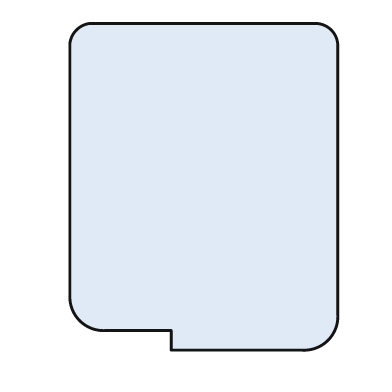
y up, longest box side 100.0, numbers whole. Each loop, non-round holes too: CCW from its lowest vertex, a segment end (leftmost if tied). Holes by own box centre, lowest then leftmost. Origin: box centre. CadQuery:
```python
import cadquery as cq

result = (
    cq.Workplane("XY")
    .moveTo(-10.0, -50.0)
    .lineTo(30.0, -50.0)
    .threePointArc((38.0, -47.0), (41.0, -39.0))
    .lineTo(41.0, 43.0)
    .threePointArc((39.0, 48.0), (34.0, 50.0))
    .lineTo(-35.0, 50.0)
    .threePointArc((-39.0, 48.0), (-41.0, 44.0))
    .lineTo(-41.0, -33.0)
    .threePointArc((-38.0, -41.0), (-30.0, -44.0))
    .lineTo(-10.0, -44.0)
    .close()
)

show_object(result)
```